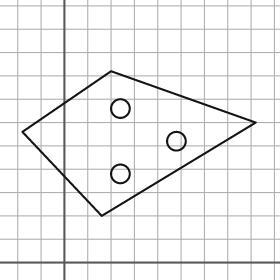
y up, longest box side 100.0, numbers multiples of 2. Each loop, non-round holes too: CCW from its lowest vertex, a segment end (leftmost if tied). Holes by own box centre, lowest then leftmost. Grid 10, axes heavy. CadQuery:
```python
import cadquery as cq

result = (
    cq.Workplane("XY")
    .moveTo(16.0, 20.0)
    .lineTo(82.0, 60.0)
    .lineTo(20.0, 82.0)
    .lineTo(-18.0, 56.0)
    .close()
    .moveTo(24.0, 38.0)
    .circle(4.0)
    .moveTo(48.0, 52.0)
    .circle(4.0)
    .moveTo(24.0, 66.0)
    .circle(4.0)
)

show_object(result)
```